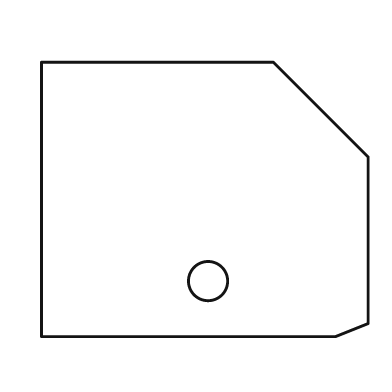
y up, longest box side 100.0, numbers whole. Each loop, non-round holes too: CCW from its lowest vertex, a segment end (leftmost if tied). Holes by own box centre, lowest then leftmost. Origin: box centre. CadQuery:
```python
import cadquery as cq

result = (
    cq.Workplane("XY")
    .moveTo(-50.0, -42.0)
    .lineTo(40.0, -42.0)
    .lineTo(50.0, -38.0)
    .lineTo(50.0, 13.0)
    .lineTo(21.0, 42.0)
    .lineTo(-50.0, 42.0)
    .close()
    .moveTo(1.0, -25.0)
    .circle(6.0)
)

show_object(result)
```